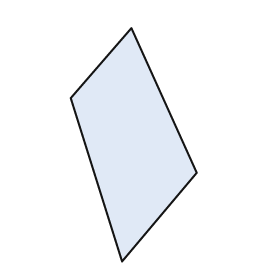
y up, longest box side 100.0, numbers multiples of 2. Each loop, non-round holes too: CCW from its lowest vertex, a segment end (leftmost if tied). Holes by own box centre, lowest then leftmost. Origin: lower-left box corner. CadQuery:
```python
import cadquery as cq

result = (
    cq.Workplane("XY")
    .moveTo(22.0, 0.0)
    .lineTo(54.0, 38.0)
    .lineTo(26.0, 100.0)
    .lineTo(0.0, 70.0)
    .close()
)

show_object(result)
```